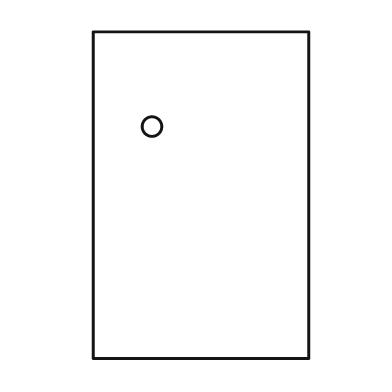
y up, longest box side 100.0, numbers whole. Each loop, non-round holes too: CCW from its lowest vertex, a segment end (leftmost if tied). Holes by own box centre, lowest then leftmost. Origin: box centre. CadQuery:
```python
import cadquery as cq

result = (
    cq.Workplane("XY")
    .moveTo(-33.0, -50.0)
    .lineTo(33.0, -50.0)
    .lineTo(33.0, 50.0)
    .lineTo(-33.0, 50.0)
    .close()
    .moveTo(-15.0, 21.0)
    .circle(3.0)
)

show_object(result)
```